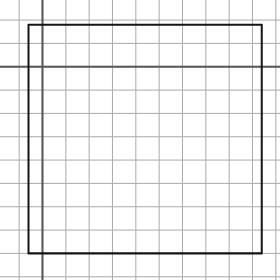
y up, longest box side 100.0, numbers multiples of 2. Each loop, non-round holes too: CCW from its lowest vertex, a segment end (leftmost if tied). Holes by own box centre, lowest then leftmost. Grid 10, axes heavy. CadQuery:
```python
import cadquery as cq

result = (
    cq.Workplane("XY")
    .moveTo(-6.0, -80.0)
    .lineTo(94.0, -80.0)
    .lineTo(94.0, 18.0)
    .lineTo(-6.0, 18.0)
    .close()
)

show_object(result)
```